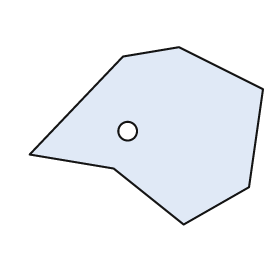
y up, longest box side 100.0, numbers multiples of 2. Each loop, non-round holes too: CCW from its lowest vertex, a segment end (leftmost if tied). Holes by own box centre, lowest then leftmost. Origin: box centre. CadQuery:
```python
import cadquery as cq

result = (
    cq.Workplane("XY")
    .moveTo(16.0, -38.0)
    .lineTo(44.0, -22.0)
    .lineTo(50.0, 20.0)
    .lineTo(14.0, 38.0)
    .lineTo(-10.0, 34.0)
    .lineTo(-50.0, -8.0)
    .lineTo(-14.0, -14.0)
    .close()
    .moveTo(-8.0, 2.0)
    .circle(4.0)
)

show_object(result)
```